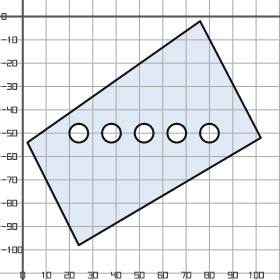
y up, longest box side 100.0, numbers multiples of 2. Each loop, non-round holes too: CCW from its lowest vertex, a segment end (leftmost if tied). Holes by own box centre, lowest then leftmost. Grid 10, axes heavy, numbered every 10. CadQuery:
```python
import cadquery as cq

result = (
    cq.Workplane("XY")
    .moveTo(24.0, -98.0)
    .lineTo(102.0, -52.0)
    .lineTo(76.0, -2.0)
    .lineTo(2.0, -54.0)
    .close()
    .moveTo(24.0, -50.0)
    .circle(4.0)
    .moveTo(38.0, -50.0)
    .circle(4.0)
    .moveTo(52.0, -50.0)
    .circle(4.0)
    .moveTo(66.0, -50.0)
    .circle(4.0)
    .moveTo(80.0, -50.0)
    .circle(4.0)
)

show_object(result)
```